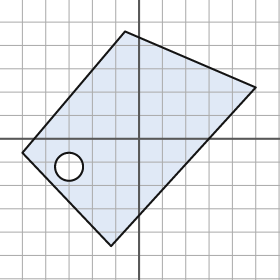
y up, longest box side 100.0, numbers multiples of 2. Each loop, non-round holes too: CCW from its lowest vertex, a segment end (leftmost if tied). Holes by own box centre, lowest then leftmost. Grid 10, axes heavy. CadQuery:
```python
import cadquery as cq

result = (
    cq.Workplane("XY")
    .moveTo(-12.0, -46.0)
    .lineTo(50.0, 22.0)
    .lineTo(-6.0, 46.0)
    .lineTo(-50.0, -6.0)
    .close()
    .moveTo(-30.0, -12.0)
    .circle(6.0)
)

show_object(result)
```